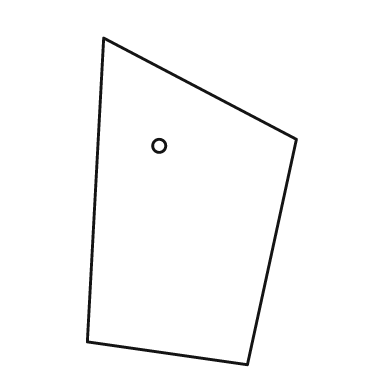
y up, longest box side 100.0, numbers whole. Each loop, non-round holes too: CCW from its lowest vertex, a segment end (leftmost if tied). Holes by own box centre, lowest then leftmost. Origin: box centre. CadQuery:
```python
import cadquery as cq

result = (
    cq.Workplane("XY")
    .moveTo(17.0, -50.0)
    .lineTo(32.0, 19.0)
    .lineTo(-27.0, 50.0)
    .lineTo(-32.0, -43.0)
    .close()
    .moveTo(-10.0, 17.0)
    .circle(2.0)
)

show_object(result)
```